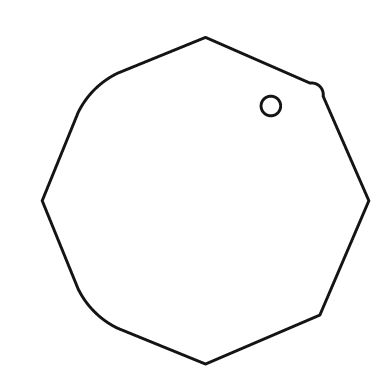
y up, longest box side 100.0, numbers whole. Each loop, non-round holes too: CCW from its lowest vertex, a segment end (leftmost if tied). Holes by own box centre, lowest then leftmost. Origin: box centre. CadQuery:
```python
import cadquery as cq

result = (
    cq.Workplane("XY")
    .moveTo(0.0, -50.0)
    .lineTo(35.0, -35.0)
    .lineTo(50.0, 0.0)
    .lineTo(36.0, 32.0)
    .threePointArc((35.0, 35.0), (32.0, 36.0))
    .lineTo(0.0, 50.0)
    .lineTo(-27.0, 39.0)
    .threePointArc((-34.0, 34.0), (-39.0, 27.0))
    .lineTo(-50.0, 0.0)
    .lineTo(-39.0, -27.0)
    .threePointArc((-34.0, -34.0), (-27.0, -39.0))
    .close()
    .moveTo(20.0, 29.0)
    .circle(3.0)
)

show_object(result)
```